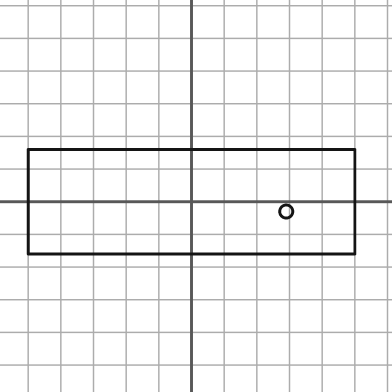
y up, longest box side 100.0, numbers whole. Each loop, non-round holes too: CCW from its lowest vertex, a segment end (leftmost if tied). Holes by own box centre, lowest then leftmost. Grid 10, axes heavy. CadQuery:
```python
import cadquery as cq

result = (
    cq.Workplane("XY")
    .moveTo(-50.0, -16.0)
    .lineTo(50.0, -16.0)
    .lineTo(50.0, 16.0)
    .lineTo(-50.0, 16.0)
    .close()
    .moveTo(29.0, -3.0)
    .circle(2.0)
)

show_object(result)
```